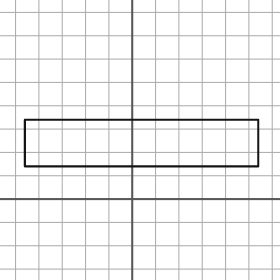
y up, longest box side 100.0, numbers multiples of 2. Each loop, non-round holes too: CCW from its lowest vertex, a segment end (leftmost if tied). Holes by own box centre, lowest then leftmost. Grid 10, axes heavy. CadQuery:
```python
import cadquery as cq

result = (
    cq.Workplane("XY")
    .moveTo(-46.0, 14.0)
    .lineTo(54.0, 14.0)
    .lineTo(54.0, 34.0)
    .lineTo(-46.0, 34.0)
    .close()
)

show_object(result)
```